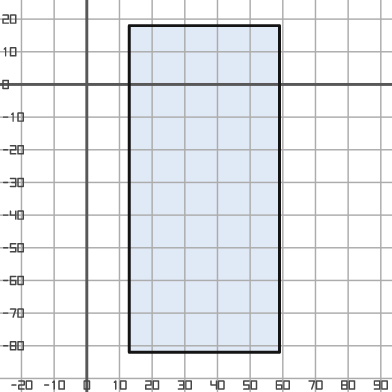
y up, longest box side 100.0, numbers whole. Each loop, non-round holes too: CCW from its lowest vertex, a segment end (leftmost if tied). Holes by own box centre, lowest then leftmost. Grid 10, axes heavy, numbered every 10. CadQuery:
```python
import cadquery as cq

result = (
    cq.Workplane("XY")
    .moveTo(13.0, -82.0)
    .lineTo(59.0, -82.0)
    .lineTo(59.0, 18.0)
    .lineTo(13.0, 18.0)
    .close()
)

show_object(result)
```